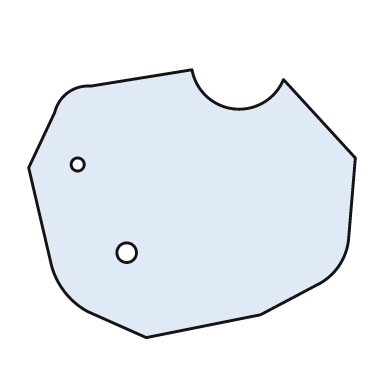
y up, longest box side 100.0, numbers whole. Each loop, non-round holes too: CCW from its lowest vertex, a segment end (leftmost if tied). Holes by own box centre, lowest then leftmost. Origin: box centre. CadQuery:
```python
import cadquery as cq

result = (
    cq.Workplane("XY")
    .moveTo(-14.0, -41.0)
    .lineTo(21.0, -34.0)
    .lineTo(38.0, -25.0)
    .threePointArc((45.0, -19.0), (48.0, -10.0))
    .lineTo(50.0, 14.0)
    .lineTo(28.0, 38.0)
    .threePointArc((13.0, 29.0), (0.0, 41.0))
    .lineTo(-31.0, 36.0)
    .threePointArc((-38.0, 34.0), (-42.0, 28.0))
    .lineTo(-50.0, 11.0)
    .lineTo(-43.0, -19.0)
    .threePointArc((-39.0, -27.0), (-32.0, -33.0))
    .close()
    .moveTo(-20.0, -15.0)
    .circle(3.0)
    .moveTo(-35.0, 12.0)
    .circle(2.0)
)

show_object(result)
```